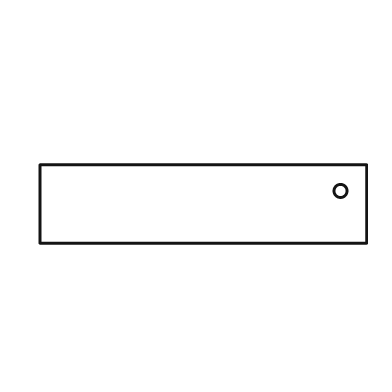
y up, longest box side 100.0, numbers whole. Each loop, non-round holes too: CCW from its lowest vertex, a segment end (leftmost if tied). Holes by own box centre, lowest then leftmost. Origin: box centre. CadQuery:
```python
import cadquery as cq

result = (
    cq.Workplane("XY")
    .moveTo(-50.0, -12.0)
    .lineTo(50.0, -12.0)
    .lineTo(50.0, 12.0)
    .lineTo(-50.0, 12.0)
    .close()
    .moveTo(42.0, 4.0)
    .circle(2.0)
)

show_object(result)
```